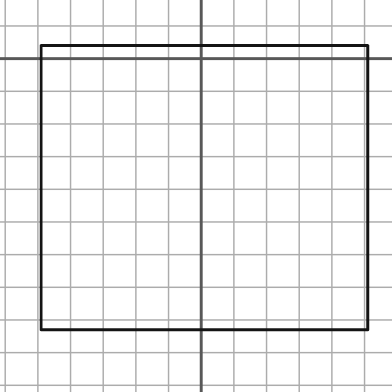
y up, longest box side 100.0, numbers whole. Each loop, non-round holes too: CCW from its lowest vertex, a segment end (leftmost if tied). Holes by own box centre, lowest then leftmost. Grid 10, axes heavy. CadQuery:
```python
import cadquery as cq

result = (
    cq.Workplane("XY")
    .moveTo(-49.0, -83.0)
    .lineTo(51.0, -83.0)
    .lineTo(51.0, 4.0)
    .lineTo(-49.0, 4.0)
    .close()
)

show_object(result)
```